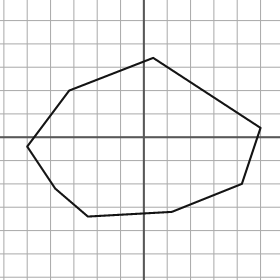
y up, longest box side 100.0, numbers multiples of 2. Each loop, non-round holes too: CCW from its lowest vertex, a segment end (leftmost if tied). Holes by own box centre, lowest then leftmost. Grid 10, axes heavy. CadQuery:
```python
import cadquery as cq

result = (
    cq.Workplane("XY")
    .moveTo(-24.0, -34.0)
    .lineTo(12.0, -32.0)
    .lineTo(42.0, -20.0)
    .lineTo(50.0, 4.0)
    .lineTo(4.0, 34.0)
    .lineTo(-32.0, 20.0)
    .lineTo(-50.0, -4.0)
    .lineTo(-38.0, -22.0)
    .close()
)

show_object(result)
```